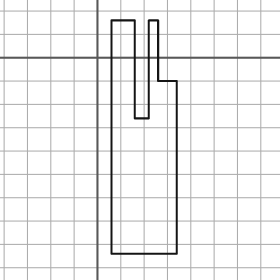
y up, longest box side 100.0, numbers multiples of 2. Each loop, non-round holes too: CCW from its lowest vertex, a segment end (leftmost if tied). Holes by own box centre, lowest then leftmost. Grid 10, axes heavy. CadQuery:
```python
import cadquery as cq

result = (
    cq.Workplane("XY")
    .moveTo(6.0, -84.0)
    .lineTo(34.0, -84.0)
    .lineTo(34.0, -10.0)
    .lineTo(26.0, -10.0)
    .lineTo(26.0, 16.0)
    .lineTo(22.0, 16.0)
    .lineTo(22.0, -26.0)
    .lineTo(16.0, -26.0)
    .lineTo(16.0, 16.0)
    .lineTo(6.0, 16.0)
    .close()
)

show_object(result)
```